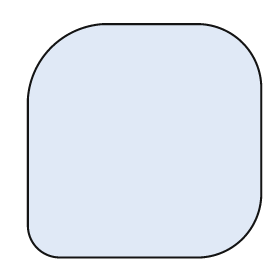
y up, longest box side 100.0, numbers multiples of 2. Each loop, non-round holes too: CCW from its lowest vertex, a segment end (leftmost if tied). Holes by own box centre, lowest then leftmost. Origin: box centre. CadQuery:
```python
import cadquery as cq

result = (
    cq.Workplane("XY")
    .moveTo(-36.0, -50.0)
    .lineTo(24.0, -50.0)
    .threePointArc((42.0, -42.0), (50.0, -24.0))
    .lineTo(50.0, 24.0)
    .threePointArc((42.0, 42.0), (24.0, 50.0))
    .lineTo(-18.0, 50.0)
    .threePointArc((-40.0, 40.0), (-50.0, 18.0))
    .lineTo(-50.0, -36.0)
    .threePointArc((-46.0, -46.0), (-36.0, -50.0))
    .close()
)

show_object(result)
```